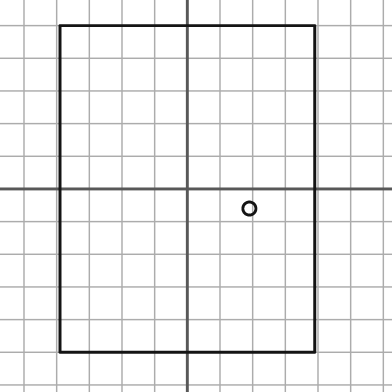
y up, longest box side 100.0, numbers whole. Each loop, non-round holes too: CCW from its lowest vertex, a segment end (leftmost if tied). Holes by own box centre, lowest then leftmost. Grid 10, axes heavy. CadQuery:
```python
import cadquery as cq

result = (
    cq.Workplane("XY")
    .moveTo(-39.0, -50.0)
    .lineTo(39.0, -50.0)
    .lineTo(39.0, 50.0)
    .lineTo(-39.0, 50.0)
    .close()
    .moveTo(19.0, -6.0)
    .circle(2.0)
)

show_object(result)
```